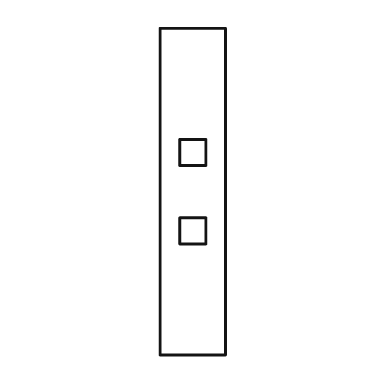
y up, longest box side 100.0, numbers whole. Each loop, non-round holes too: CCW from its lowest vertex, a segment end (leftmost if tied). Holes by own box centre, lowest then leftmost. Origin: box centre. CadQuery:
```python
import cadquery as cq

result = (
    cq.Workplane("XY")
    .moveTo(-10.0, -50.0)
    .lineTo(10.0, -50.0)
    .lineTo(10.0, 50.0)
    .lineTo(-10.0, 50.0)
    .close()
    .moveTo(-4.0, -16.0)
    .lineTo(4.0, -16.0)
    .lineTo(4.0, -8.0)
    .lineTo(-4.0, -8.0)
    .close()
    .moveTo(-4.0, 8.0)
    .lineTo(4.0, 8.0)
    .lineTo(4.0, 16.0)
    .lineTo(-4.0, 16.0)
    .close()
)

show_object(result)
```